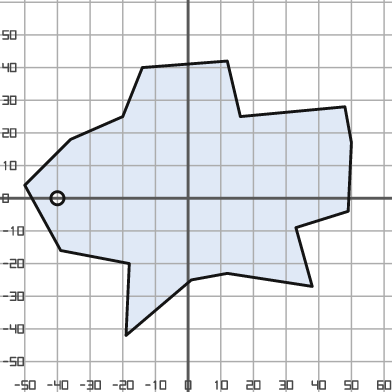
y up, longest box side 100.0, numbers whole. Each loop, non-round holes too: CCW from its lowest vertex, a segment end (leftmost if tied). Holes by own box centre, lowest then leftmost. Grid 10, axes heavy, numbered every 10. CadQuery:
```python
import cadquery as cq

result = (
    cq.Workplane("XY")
    .moveTo(-19.0, -42.0)
    .lineTo(1.0, -25.0)
    .lineTo(12.0, -23.0)
    .lineTo(38.0, -27.0)
    .lineTo(33.0, -9.0)
    .lineTo(49.0, -4.0)
    .lineTo(50.0, 17.0)
    .lineTo(48.0, 28.0)
    .lineTo(16.0, 25.0)
    .lineTo(12.0, 42.0)
    .lineTo(-14.0, 40.0)
    .lineTo(-20.0, 25.0)
    .lineTo(-36.0, 18.0)
    .lineTo(-50.0, 4.0)
    .lineTo(-39.0, -16.0)
    .lineTo(-18.0, -20.0)
    .close()
    .moveTo(-40.0, 0.0)
    .circle(2.0)
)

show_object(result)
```